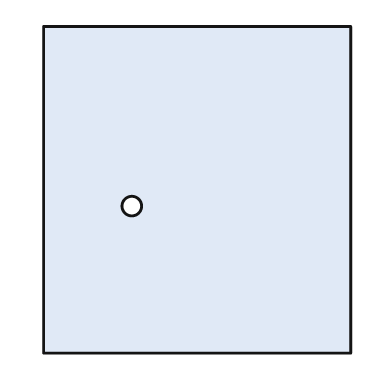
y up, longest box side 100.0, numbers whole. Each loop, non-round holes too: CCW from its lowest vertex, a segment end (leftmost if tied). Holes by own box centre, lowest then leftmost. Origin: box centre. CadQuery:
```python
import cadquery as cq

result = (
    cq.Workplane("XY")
    .moveTo(-47.0, -50.0)
    .lineTo(47.0, -50.0)
    .lineTo(47.0, 50.0)
    .lineTo(-47.0, 50.0)
    .close()
    .moveTo(-20.0, -5.0)
    .circle(3.0)
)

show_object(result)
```